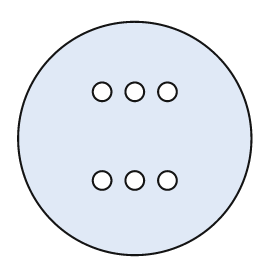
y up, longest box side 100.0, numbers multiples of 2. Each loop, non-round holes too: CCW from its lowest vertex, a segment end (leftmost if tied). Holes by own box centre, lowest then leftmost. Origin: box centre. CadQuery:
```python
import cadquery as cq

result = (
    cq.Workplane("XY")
    .moveTo(0.0, 0.0)
    .circle(50.0)
    .moveTo(-14.0, -18.0)
    .circle(4.0)
    .moveTo(0.0, -18.0)
    .circle(4.0)
    .moveTo(14.0, -18.0)
    .circle(4.0)
    .moveTo(-14.0, 20.0)
    .circle(4.0)
    .moveTo(0.0, 20.0)
    .circle(4.0)
    .moveTo(14.0, 20.0)
    .circle(4.0)
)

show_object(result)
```